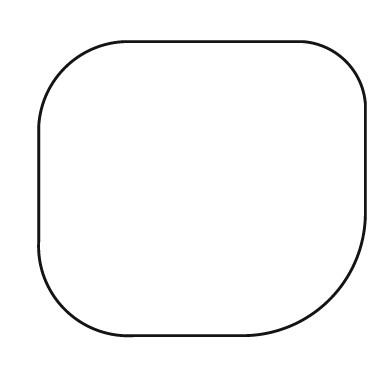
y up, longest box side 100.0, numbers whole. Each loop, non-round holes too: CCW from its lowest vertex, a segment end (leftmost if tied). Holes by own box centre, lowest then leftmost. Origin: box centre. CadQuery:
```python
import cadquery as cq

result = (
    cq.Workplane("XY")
    .moveTo(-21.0, -45.0)
    .lineTo(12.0, -45.0)
    .threePointArc((39.0, -34.0), (50.0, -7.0))
    .lineTo(50.0, 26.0)
    .threePointArc((44.0, 39.0), (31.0, 45.0))
    .lineTo(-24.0, 45.0)
    .threePointArc((-42.0, 37.0), (-50.0, 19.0))
    .lineTo(-50.0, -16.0)
    .threePointArc((-42.0, -37.0), (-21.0, -45.0))
    .close()
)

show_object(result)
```